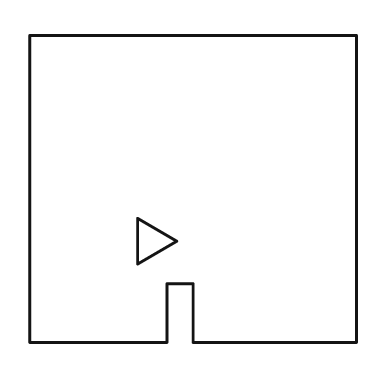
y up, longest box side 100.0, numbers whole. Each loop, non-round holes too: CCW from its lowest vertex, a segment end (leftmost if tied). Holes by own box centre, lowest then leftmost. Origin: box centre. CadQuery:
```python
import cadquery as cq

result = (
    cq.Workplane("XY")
    .moveTo(-50.0, -47.0)
    .lineTo(-8.0, -47.0)
    .lineTo(-8.0, -29.0)
    .lineTo(0.0, -29.0)
    .lineTo(0.0, -47.0)
    .lineTo(50.0, -47.0)
    .lineTo(50.0, 47.0)
    .lineTo(-50.0, 47.0)
    .close()
    .moveTo(-17.0, -23.0)
    .lineTo(-5.0, -16.0)
    .lineTo(-17.0, -9.0)
    .close()
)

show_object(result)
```